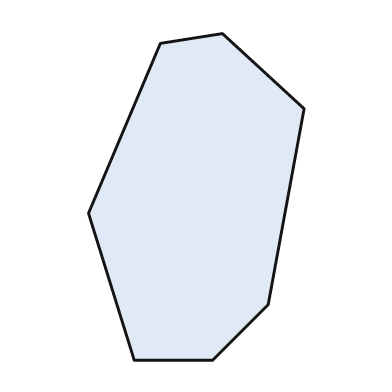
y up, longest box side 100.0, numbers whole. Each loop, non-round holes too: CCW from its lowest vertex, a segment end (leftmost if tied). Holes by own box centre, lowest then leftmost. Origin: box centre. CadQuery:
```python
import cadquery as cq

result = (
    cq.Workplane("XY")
    .moveTo(-19.0, -50.0)
    .lineTo(5.0, -50.0)
    .lineTo(22.0, -33.0)
    .lineTo(33.0, 27.0)
    .lineTo(8.0, 50.0)
    .lineTo(-11.0, 47.0)
    .lineTo(-33.0, -5.0)
    .close()
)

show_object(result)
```